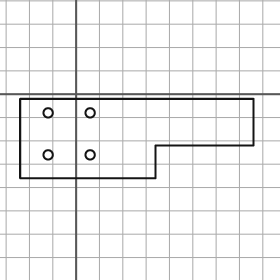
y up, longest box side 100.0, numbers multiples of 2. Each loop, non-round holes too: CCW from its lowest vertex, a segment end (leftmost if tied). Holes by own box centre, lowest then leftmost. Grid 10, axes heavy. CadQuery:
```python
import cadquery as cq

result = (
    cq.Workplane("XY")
    .moveTo(-24.0, -36.0)
    .lineTo(34.0, -36.0)
    .lineTo(34.0, -22.0)
    .lineTo(76.0, -22.0)
    .lineTo(76.0, -2.0)
    .lineTo(-24.0, -2.0)
    .close()
    .moveTo(-12.0, -26.0)
    .circle(2.0)
    .moveTo(6.0, -26.0)
    .circle(2.0)
    .moveTo(-12.0, -8.0)
    .circle(2.0)
    .moveTo(6.0, -8.0)
    .circle(2.0)
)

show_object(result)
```